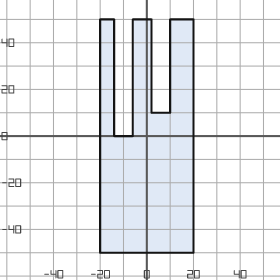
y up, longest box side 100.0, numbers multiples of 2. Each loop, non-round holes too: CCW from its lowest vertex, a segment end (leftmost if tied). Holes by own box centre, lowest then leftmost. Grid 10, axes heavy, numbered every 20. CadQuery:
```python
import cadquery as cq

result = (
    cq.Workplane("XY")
    .moveTo(-20.0, -50.0)
    .lineTo(20.0, -50.0)
    .lineTo(20.0, 50.0)
    .lineTo(10.0, 50.0)
    .lineTo(10.0, 10.0)
    .lineTo(2.0, 10.0)
    .lineTo(2.0, 50.0)
    .lineTo(-6.0, 50.0)
    .lineTo(-6.0, 0.0)
    .lineTo(-14.0, 0.0)
    .lineTo(-14.0, 50.0)
    .lineTo(-20.0, 50.0)
    .close()
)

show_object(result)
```